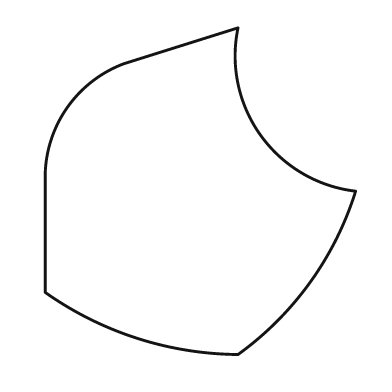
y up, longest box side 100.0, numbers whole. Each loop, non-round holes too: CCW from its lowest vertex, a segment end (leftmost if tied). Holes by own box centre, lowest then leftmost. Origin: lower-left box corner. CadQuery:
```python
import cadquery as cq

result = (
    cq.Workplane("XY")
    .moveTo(59.0, 0.0)
    .threePointArc((81.0, 22.0), (95.0, 50.0))
    .threePointArc((66.0, 67.0), (59.0, 100.0))
    .lineTo(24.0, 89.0)
    .threePointArc((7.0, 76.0), (0.0, 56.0))
    .lineTo(0.0, 19.0)
    .threePointArc((28.0, 5.0), (59.0, 0.0))
    .close()
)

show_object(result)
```